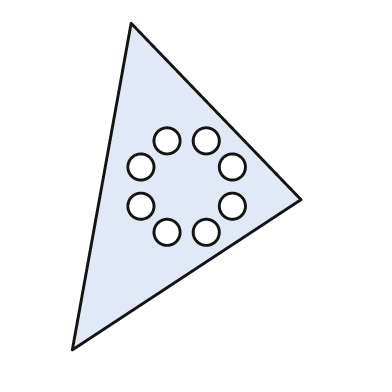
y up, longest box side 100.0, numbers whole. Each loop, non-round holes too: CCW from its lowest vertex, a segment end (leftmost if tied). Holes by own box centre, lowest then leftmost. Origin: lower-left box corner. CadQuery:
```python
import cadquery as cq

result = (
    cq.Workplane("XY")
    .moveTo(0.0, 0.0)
    .lineTo(70.0, 46.0)
    .lineTo(18.0, 100.0)
    .close()
    .moveTo(29.0, 36.0)
    .circle(4.0)
    .moveTo(41.0, 36.0)
    .circle(4.0)
    .moveTo(21.0, 44.0)
    .circle(4.0)
    .moveTo(49.0, 44.0)
    .circle(4.0)
    .moveTo(21.0, 56.0)
    .circle(4.0)
    .moveTo(49.0, 56.0)
    .circle(4.0)
    .moveTo(29.0, 64.0)
    .circle(4.0)
    .moveTo(41.0, 64.0)
    .circle(4.0)
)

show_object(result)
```